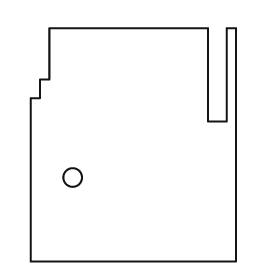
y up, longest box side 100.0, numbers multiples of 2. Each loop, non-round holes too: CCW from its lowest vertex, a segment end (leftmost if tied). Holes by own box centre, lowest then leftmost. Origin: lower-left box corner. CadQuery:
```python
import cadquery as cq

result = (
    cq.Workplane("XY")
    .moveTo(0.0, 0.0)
    .lineTo(88.0, 0.0)
    .lineTo(88.0, 100.0)
    .lineTo(84.0, 100.0)
    .lineTo(84.0, 60.0)
    .lineTo(76.0, 60.0)
    .lineTo(76.0, 100.0)
    .lineTo(8.0, 100.0)
    .lineTo(8.0, 78.0)
    .lineTo(4.0, 78.0)
    .lineTo(4.0, 70.0)
    .lineTo(0.0, 70.0)
    .close()
    .moveTo(18.0, 36.0)
    .circle(4.0)
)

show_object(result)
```